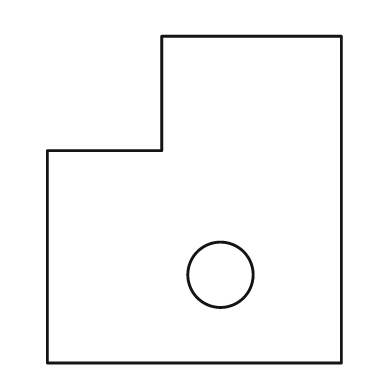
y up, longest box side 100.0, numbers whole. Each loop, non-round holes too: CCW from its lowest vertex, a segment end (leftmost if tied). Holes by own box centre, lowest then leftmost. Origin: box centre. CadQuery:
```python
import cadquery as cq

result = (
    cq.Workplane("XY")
    .moveTo(-45.0, -50.0)
    .lineTo(45.0, -50.0)
    .lineTo(45.0, 50.0)
    .lineTo(-10.0, 50.0)
    .lineTo(-10.0, 15.0)
    .lineTo(-45.0, 15.0)
    .close()
    .moveTo(8.0, -23.0)
    .circle(10.0)
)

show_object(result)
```